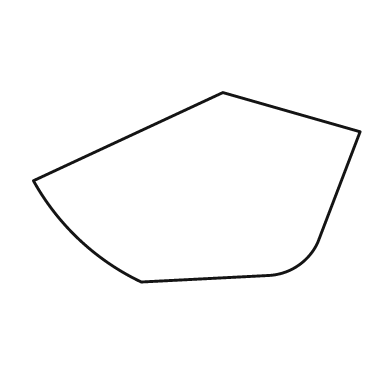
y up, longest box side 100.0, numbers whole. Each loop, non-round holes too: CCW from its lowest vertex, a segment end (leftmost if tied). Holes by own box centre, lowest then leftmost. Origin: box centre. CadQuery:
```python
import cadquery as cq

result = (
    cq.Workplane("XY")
    .moveTo(-17.0, -29.0)
    .lineTo(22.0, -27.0)
    .threePointArc((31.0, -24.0), (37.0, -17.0))
    .lineTo(50.0, 17.0)
    .lineTo(8.0, 29.0)
    .lineTo(-50.0, 2.0)
    .threePointArc((-36.0, -16.0), (-17.0, -29.0))
    .close()
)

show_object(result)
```